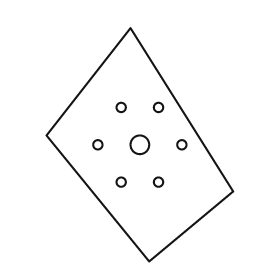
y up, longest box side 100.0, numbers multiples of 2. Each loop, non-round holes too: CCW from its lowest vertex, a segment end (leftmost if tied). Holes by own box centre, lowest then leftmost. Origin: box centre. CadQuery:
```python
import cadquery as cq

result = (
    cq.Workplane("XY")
    .moveTo(4.0, -50.0)
    .lineTo(40.0, -20.0)
    .lineTo(-4.0, 50.0)
    .lineTo(-40.0, 4.0)
    .close()
    .moveTo(-8.0, -16.0)
    .circle(2.0)
    .moveTo(8.0, -16.0)
    .circle(2.0)
    .moveTo(-18.0, 0.0)
    .circle(2.0)
    .moveTo(0.0, 0.0)
    .circle(4.0)
    .moveTo(18.0, 0.0)
    .circle(2.0)
    .moveTo(-8.0, 16.0)
    .circle(2.0)
    .moveTo(8.0, 16.0)
    .circle(2.0)
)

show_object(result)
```